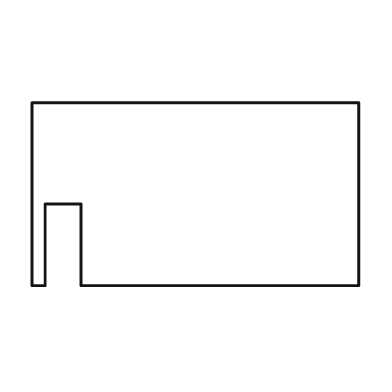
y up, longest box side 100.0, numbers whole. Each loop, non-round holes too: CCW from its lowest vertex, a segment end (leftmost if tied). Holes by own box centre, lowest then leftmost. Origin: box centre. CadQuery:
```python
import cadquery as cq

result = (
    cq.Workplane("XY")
    .moveTo(-50.0, -28.0)
    .lineTo(-46.0, -28.0)
    .lineTo(-46.0, -3.0)
    .lineTo(-35.0, -3.0)
    .lineTo(-35.0, -28.0)
    .lineTo(50.0, -28.0)
    .lineTo(50.0, 28.0)
    .lineTo(-50.0, 28.0)
    .close()
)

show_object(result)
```